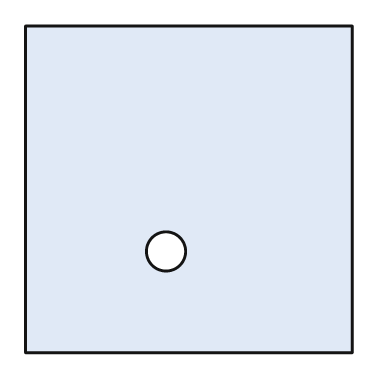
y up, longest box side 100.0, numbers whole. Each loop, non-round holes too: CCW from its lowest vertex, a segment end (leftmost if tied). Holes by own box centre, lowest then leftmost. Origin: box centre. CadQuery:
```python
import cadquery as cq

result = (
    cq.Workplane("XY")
    .moveTo(-50.0, -50.0)
    .lineTo(50.0, -50.0)
    .lineTo(50.0, 50.0)
    .lineTo(-50.0, 50.0)
    .close()
    .moveTo(-7.0, -19.0)
    .circle(6.0)
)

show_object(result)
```